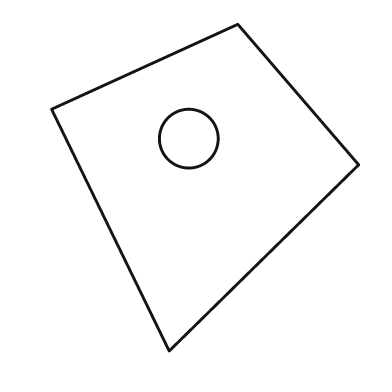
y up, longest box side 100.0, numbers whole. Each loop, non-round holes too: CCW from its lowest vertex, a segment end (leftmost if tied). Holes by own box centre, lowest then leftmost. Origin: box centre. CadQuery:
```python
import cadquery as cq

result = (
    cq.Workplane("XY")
    .moveTo(-11.0, -50.0)
    .lineTo(47.0, 7.0)
    .lineTo(10.0, 50.0)
    .lineTo(-47.0, 24.0)
    .close()
    .moveTo(-5.0, 15.0)
    .circle(9.0)
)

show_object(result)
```